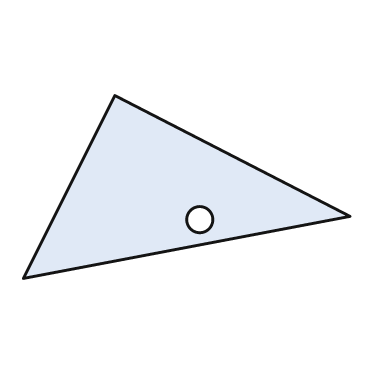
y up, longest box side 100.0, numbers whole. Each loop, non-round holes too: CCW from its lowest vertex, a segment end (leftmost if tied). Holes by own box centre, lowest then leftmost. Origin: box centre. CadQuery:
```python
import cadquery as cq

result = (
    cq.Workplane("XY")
    .moveTo(-50.0, -28.0)
    .lineTo(50.0, -9.0)
    .lineTo(-22.0, 28.0)
    .close()
    .moveTo(4.0, -10.0)
    .circle(4.0)
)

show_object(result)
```